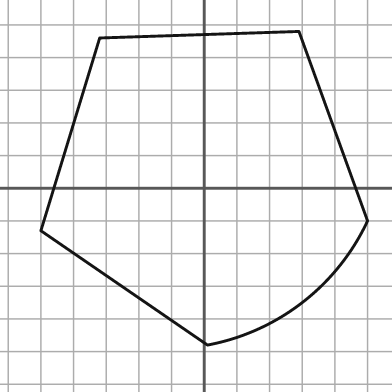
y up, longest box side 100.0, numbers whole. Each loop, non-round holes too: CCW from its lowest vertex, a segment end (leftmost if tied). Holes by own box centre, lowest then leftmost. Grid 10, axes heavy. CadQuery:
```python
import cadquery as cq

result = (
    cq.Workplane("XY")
    .moveTo(1.0, -48.0)
    .threePointArc((30.0, -35.0), (50.0, -10.0))
    .lineTo(29.0, 48.0)
    .lineTo(-32.0, 46.0)
    .lineTo(-50.0, -13.0)
    .close()
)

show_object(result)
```